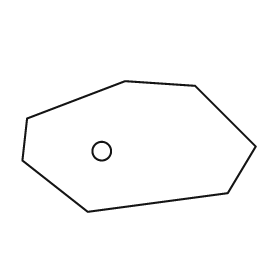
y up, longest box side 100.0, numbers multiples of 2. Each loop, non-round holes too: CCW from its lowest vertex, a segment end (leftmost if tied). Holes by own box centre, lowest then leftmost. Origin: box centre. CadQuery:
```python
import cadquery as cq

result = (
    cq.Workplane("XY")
    .moveTo(-22.0, -28.0)
    .lineTo(38.0, -20.0)
    .lineTo(50.0, 0.0)
    .lineTo(24.0, 26.0)
    .lineTo(-6.0, 28.0)
    .lineTo(-48.0, 12.0)
    .lineTo(-50.0, -6.0)
    .close()
    .moveTo(-16.0, -2.0)
    .circle(4.0)
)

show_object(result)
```